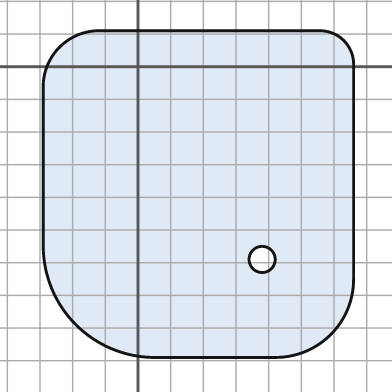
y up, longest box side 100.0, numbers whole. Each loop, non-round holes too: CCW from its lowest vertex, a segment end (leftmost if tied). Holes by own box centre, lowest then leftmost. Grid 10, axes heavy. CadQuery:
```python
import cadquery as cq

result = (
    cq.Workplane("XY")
    .moveTo(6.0, -89.0)
    .lineTo(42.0, -89.0)
    .threePointArc((59.0, -82.0), (66.0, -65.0))
    .lineTo(66.0, 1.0)
    .threePointArc((63.0, 8.0), (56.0, 11.0))
    .lineTo(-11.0, 11.0)
    .threePointArc((-24.0, 6.0), (-29.0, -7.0))
    .lineTo(-29.0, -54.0)
    .threePointArc((-19.0, -79.0), (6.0, -89.0))
    .close()
    .moveTo(38.0, -59.0)
    .circle(4.0)
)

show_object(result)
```